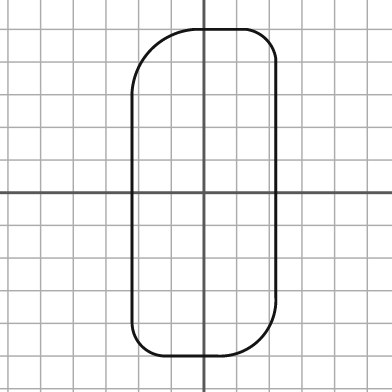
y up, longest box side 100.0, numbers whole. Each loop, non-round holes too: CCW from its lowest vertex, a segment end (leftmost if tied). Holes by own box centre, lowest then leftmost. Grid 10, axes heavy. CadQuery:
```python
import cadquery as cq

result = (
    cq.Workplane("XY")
    .moveTo(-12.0, -50.0)
    .lineTo(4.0, -50.0)
    .threePointArc((17.0, -45.0), (22.0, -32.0))
    .lineTo(22.0, 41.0)
    .threePointArc((19.0, 47.0), (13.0, 50.0))
    .lineTo(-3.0, 50.0)
    .threePointArc((-16.0, 44.0), (-22.0, 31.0))
    .lineTo(-22.0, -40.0)
    .threePointArc((-19.0, -47.0), (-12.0, -50.0))
    .close()
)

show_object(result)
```